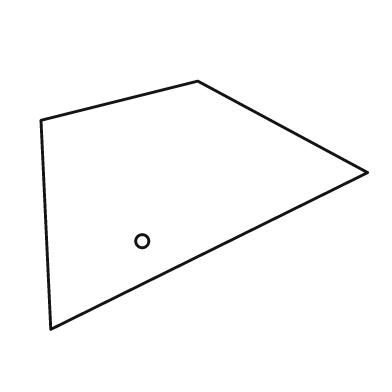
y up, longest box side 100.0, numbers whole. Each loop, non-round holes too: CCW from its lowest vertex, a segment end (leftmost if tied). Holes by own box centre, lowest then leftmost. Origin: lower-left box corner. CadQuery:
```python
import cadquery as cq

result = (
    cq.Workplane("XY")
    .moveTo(3.0, 0.0)
    .lineTo(100.0, 48.0)
    .lineTo(48.0, 76.0)
    .lineTo(0.0, 64.0)
    .close()
    .moveTo(31.0, 27.0)
    .circle(2.0)
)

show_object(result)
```